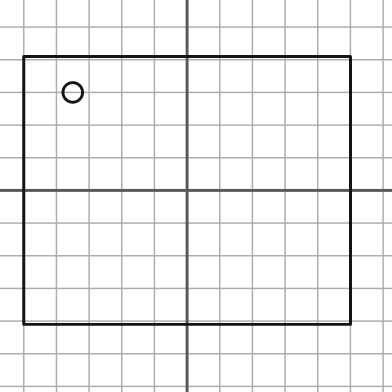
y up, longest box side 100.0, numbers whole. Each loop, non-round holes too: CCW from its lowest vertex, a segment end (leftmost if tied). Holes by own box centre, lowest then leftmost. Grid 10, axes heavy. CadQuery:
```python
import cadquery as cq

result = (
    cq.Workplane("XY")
    .moveTo(-50.0, -41.0)
    .lineTo(50.0, -41.0)
    .lineTo(50.0, 41.0)
    .lineTo(-50.0, 41.0)
    .close()
    .moveTo(-35.0, 30.0)
    .circle(3.0)
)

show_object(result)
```